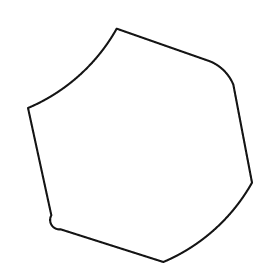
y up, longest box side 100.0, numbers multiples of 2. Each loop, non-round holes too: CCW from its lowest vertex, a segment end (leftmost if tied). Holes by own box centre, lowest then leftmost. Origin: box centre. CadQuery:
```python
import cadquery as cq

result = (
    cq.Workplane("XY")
    .moveTo(10.0, -50.0)
    .threePointArc((32.0, -36.0), (48.0, -16.0))
    .lineTo(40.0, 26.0)
    .threePointArc((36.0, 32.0), (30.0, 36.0))
    .lineTo(-10.0, 50.0)
    .threePointArc((-26.0, 30.0), (-48.0, 16.0))
    .lineTo(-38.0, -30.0)
    .threePointArc((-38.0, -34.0), (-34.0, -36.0))
    .close()
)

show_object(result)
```